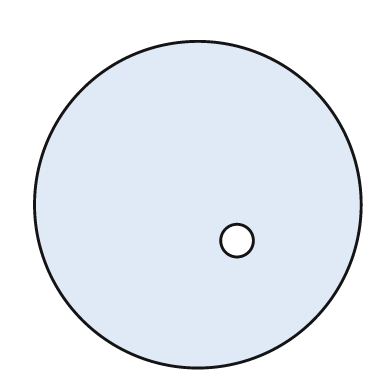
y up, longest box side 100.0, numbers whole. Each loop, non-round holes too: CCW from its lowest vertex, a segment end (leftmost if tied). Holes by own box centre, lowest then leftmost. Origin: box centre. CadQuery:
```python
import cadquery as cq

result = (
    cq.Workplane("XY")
    .moveTo(0.0, 0.0)
    .circle(50.0)
    .moveTo(12.0, -11.0)
    .circle(5.0)
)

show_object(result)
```